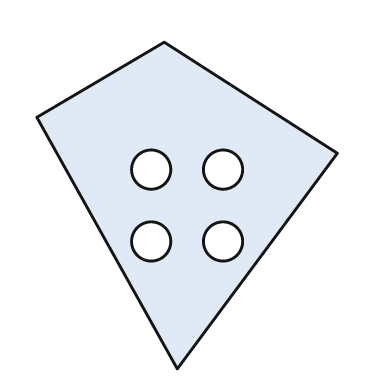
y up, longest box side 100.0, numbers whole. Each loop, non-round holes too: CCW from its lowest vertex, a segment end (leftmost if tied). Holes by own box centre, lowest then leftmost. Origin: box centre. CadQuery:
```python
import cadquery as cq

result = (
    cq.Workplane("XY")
    .moveTo(-3.0, -50.0)
    .lineTo(46.0, 16.0)
    .lineTo(-7.0, 50.0)
    .lineTo(-46.0, 27.0)
    .close()
    .moveTo(-11.0, -11.0)
    .circle(6.0)
    .moveTo(11.0, -11.0)
    .circle(6.0)
    .moveTo(-11.0, 11.0)
    .circle(6.0)
    .moveTo(11.0, 11.0)
    .circle(6.0)
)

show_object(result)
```